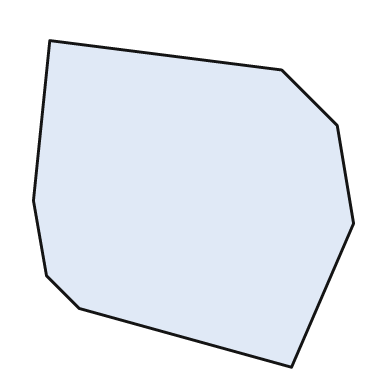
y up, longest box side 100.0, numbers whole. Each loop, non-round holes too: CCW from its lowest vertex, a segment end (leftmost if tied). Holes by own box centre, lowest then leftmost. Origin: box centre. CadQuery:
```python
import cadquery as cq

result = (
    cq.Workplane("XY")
    .moveTo(30.0, -50.0)
    .lineTo(49.0, -6.0)
    .lineTo(44.0, 24.0)
    .lineTo(27.0, 41.0)
    .lineTo(-44.0, 50.0)
    .lineTo(-49.0, 1.0)
    .lineTo(-45.0, -22.0)
    .lineTo(-35.0, -32.0)
    .close()
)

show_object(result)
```